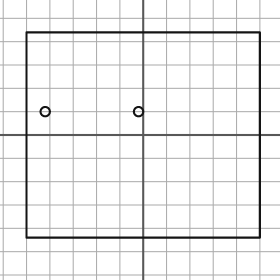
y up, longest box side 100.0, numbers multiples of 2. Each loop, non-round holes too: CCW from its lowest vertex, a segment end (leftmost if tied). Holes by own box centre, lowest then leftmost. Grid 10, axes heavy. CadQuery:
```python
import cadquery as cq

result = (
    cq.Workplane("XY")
    .moveTo(-50.0, -44.0)
    .lineTo(50.0, -44.0)
    .lineTo(50.0, 44.0)
    .lineTo(-50.0, 44.0)
    .close()
    .moveTo(-42.0, 10.0)
    .circle(2.0)
    .moveTo(-2.0, 10.0)
    .circle(2.0)
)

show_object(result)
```